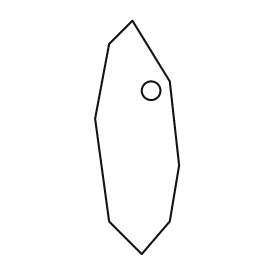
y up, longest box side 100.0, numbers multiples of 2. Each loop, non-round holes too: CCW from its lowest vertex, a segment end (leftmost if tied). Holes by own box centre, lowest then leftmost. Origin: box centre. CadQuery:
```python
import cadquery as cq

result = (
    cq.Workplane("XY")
    .moveTo(2.0, -50.0)
    .lineTo(14.0, -36.0)
    .lineTo(18.0, -12.0)
    .lineTo(14.0, 24.0)
    .lineTo(-2.0, 50.0)
    .lineTo(-12.0, 40.0)
    .lineTo(-18.0, 8.0)
    .lineTo(-12.0, -36.0)
    .close()
    .moveTo(6.0, 20.0)
    .circle(4.0)
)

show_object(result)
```